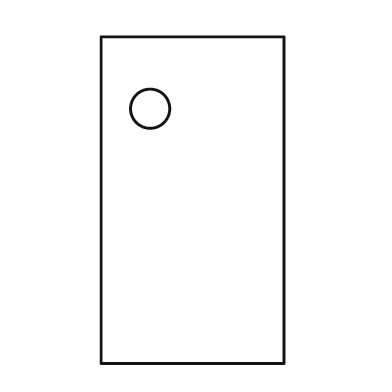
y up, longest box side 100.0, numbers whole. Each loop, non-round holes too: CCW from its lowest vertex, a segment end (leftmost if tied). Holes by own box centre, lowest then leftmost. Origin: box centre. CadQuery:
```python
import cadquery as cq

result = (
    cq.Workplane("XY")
    .moveTo(-28.0, -50.0)
    .lineTo(28.0, -50.0)
    .lineTo(28.0, 50.0)
    .lineTo(-28.0, 50.0)
    .close()
    .moveTo(-13.0, 28.0)
    .circle(6.0)
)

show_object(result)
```